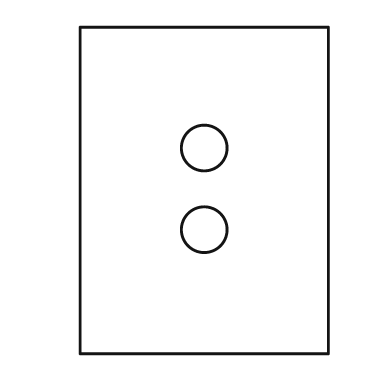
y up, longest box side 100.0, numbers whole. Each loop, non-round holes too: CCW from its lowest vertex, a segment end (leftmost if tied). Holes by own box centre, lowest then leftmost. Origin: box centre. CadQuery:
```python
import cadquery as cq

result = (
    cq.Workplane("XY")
    .moveTo(-38.0, -50.0)
    .lineTo(38.0, -50.0)
    .lineTo(38.0, 50.0)
    .lineTo(-38.0, 50.0)
    .close()
    .moveTo(0.0, -12.0)
    .circle(7.0)
    .moveTo(0.0, 13.0)
    .circle(7.0)
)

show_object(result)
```